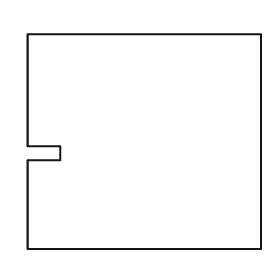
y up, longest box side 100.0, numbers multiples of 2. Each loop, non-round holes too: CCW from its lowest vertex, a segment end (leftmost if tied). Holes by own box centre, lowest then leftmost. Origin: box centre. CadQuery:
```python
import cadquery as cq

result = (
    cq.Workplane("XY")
    .moveTo(-50.0, -46.0)
    .lineTo(50.0, -46.0)
    .lineTo(50.0, 46.0)
    .lineTo(-50.0, 46.0)
    .lineTo(-50.0, -2.0)
    .lineTo(-36.0, -2.0)
    .lineTo(-36.0, -8.0)
    .lineTo(-50.0, -8.0)
    .close()
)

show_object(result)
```